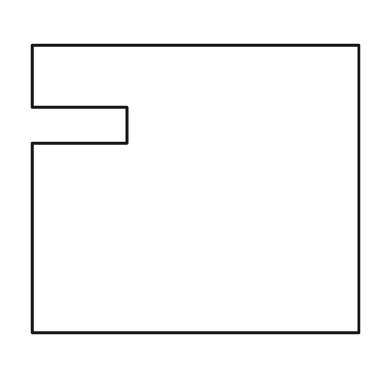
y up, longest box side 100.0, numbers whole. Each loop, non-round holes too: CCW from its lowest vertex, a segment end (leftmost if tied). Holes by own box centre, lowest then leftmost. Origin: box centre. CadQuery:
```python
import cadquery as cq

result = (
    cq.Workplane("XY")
    .moveTo(-50.0, -44.0)
    .lineTo(50.0, -44.0)
    .lineTo(50.0, 44.0)
    .lineTo(-50.0, 44.0)
    .lineTo(-50.0, 25.0)
    .lineTo(-21.0, 25.0)
    .lineTo(-21.0, 14.0)
    .lineTo(-50.0, 14.0)
    .close()
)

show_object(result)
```